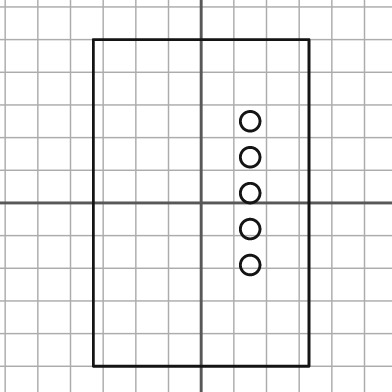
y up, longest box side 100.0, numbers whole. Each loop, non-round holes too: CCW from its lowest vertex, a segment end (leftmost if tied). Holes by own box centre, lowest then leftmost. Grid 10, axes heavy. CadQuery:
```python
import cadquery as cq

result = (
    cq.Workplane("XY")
    .moveTo(-33.0, -50.0)
    .lineTo(33.0, -50.0)
    .lineTo(33.0, 50.0)
    .lineTo(-33.0, 50.0)
    .close()
    .moveTo(15.0, -19.0)
    .circle(3.0)
    .moveTo(15.0, -8.0)
    .circle(3.0)
    .moveTo(15.0, 3.0)
    .circle(3.0)
    .moveTo(15.0, 14.0)
    .circle(3.0)
    .moveTo(15.0, 25.0)
    .circle(3.0)
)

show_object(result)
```